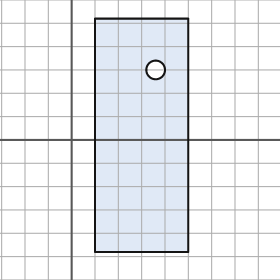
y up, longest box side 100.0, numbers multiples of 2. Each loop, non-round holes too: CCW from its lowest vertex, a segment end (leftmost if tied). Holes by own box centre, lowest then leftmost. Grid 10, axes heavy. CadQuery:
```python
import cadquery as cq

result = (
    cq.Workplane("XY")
    .moveTo(10.0, -48.0)
    .lineTo(50.0, -48.0)
    .lineTo(50.0, 52.0)
    .lineTo(10.0, 52.0)
    .close()
    .moveTo(36.0, 30.0)
    .circle(4.0)
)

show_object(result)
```